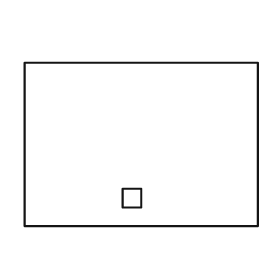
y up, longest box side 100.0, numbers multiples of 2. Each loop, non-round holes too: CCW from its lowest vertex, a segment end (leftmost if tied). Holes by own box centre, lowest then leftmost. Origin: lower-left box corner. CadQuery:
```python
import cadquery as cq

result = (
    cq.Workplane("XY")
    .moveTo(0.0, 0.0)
    .lineTo(100.0, 0.0)
    .lineTo(100.0, 70.0)
    .lineTo(0.0, 70.0)
    .close()
    .moveTo(42.0, 8.0)
    .lineTo(50.0, 8.0)
    .lineTo(50.0, 16.0)
    .lineTo(42.0, 16.0)
    .close()
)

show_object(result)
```